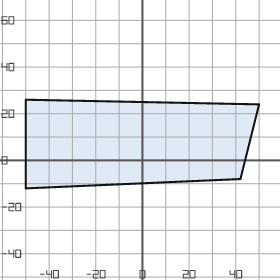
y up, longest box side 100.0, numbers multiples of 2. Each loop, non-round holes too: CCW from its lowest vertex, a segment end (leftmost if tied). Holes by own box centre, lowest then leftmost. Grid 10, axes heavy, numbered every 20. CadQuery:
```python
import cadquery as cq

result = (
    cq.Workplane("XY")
    .moveTo(-50.0, -12.0)
    .lineTo(42.0, -8.0)
    .lineTo(50.0, 24.0)
    .lineTo(-50.0, 26.0)
    .close()
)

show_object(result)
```